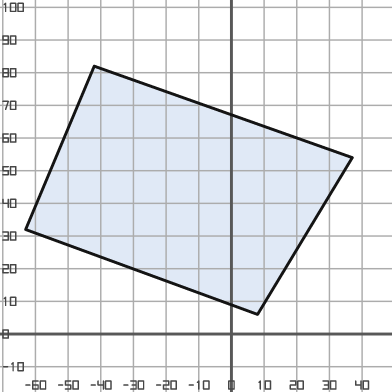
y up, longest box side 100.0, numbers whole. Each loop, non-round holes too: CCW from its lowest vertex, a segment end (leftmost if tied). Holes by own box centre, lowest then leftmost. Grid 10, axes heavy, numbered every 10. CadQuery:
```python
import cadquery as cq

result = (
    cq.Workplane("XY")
    .moveTo(8.0, 6.0)
    .lineTo(37.0, 54.0)
    .lineTo(-42.0, 82.0)
    .lineTo(-63.0, 32.0)
    .close()
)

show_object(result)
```